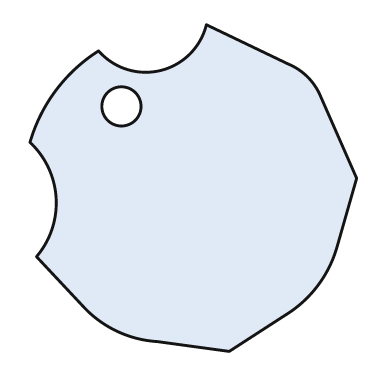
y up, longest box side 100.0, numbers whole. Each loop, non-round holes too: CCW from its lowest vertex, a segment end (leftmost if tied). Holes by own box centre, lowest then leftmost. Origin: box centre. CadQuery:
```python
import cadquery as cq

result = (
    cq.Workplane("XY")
    .moveTo(11.0, -50.0)
    .lineTo(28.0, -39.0)
    .threePointArc((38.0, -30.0), (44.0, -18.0))
    .lineTo(50.0, 3.0)
    .lineTo(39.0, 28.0)
    .threePointArc((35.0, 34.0), (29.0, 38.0))
    .lineTo(4.0, 50.0)
    .threePointArc((-10.0, 36.0), (-29.0, 42.0))
    .threePointArc((-42.0, 30.0), (-50.0, 14.0))
    .threePointArc((-42.0, -3.0), (-48.0, -21.0))
    .lineTo(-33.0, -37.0)
    .threePointArc((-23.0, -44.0), (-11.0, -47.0))
    .close()
    .moveTo(-22.0, 25.0)
    .circle(6.0)
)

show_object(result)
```